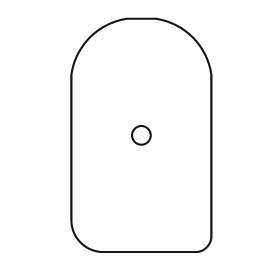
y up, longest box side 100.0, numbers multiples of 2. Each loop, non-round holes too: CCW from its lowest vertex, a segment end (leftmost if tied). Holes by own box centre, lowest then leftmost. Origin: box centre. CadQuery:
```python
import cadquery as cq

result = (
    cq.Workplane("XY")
    .moveTo(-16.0, -50.0)
    .lineTo(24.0, -50.0)
    .threePointArc((28.0, -48.0), (30.0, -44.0))
    .lineTo(30.0, 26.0)
    .threePointArc((22.0, 42.0), (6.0, 50.0))
    .lineTo(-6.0, 50.0)
    .threePointArc((-22.0, 42.0), (-30.0, 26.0))
    .lineTo(-30.0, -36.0)
    .threePointArc((-26.0, -46.0), (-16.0, -50.0))
    .close()
    .moveTo(0.0, 0.0)
    .circle(4.0)
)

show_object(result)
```